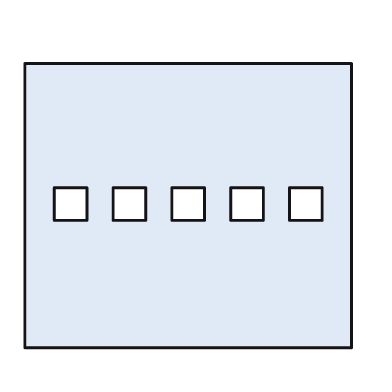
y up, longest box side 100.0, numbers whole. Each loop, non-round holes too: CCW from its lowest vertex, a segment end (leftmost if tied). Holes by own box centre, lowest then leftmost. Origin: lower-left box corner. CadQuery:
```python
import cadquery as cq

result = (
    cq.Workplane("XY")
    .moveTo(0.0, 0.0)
    .lineTo(100.0, 0.0)
    .lineTo(100.0, 87.0)
    .lineTo(0.0, 87.0)
    .close()
    .moveTo(9.0, 39.0)
    .lineTo(19.0, 39.0)
    .lineTo(19.0, 49.0)
    .lineTo(9.0, 49.0)
    .close()
    .moveTo(27.0, 39.0)
    .lineTo(37.0, 39.0)
    .lineTo(37.0, 49.0)
    .lineTo(27.0, 49.0)
    .close()
    .moveTo(45.0, 39.0)
    .lineTo(55.0, 39.0)
    .lineTo(55.0, 49.0)
    .lineTo(45.0, 49.0)
    .close()
    .moveTo(63.0, 39.0)
    .lineTo(73.0, 39.0)
    .lineTo(73.0, 49.0)
    .lineTo(63.0, 49.0)
    .close()
    .moveTo(81.0, 39.0)
    .lineTo(91.0, 39.0)
    .lineTo(91.0, 49.0)
    .lineTo(81.0, 49.0)
    .close()
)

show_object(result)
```